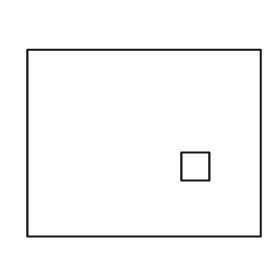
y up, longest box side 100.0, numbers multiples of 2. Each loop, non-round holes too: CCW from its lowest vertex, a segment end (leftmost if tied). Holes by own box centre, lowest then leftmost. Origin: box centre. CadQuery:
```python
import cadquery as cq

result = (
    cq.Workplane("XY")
    .moveTo(-50.0, -40.0)
    .lineTo(50.0, -40.0)
    .lineTo(50.0, 40.0)
    .lineTo(-50.0, 40.0)
    .close()
    .moveTo(16.0, -16.0)
    .lineTo(28.0, -16.0)
    .lineTo(28.0, -4.0)
    .lineTo(16.0, -4.0)
    .close()
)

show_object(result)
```